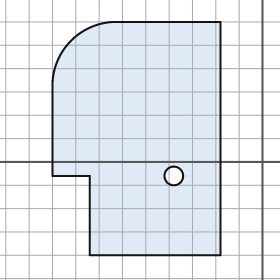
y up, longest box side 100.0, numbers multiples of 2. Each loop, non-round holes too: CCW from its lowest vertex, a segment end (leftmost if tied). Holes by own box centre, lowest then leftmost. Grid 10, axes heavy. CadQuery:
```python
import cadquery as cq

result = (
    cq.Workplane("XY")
    .moveTo(-74.0, -40.0)
    .lineTo(-18.0, -40.0)
    .lineTo(-18.0, 60.0)
    .lineTo(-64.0, 60.0)
    .threePointArc((-82.0, 52.0), (-90.0, 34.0))
    .lineTo(-90.0, -6.0)
    .lineTo(-74.0, -6.0)
    .close()
    .moveTo(-38.0, -6.0)
    .circle(4.0)
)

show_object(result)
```